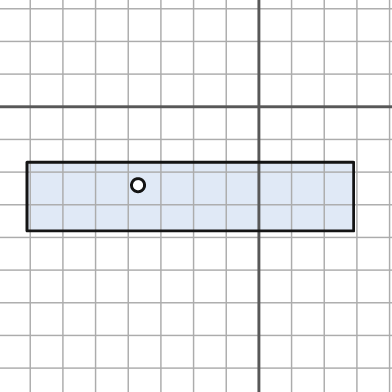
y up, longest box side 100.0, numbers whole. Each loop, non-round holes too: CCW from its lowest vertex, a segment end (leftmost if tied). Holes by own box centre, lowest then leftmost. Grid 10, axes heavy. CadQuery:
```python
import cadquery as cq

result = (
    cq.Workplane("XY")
    .moveTo(-71.0, -38.0)
    .lineTo(29.0, -38.0)
    .lineTo(29.0, -17.0)
    .lineTo(-71.0, -17.0)
    .close()
    .moveTo(-37.0, -24.0)
    .circle(2.0)
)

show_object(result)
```